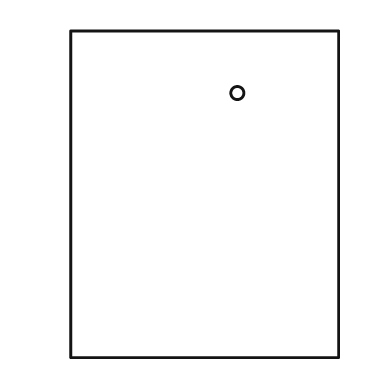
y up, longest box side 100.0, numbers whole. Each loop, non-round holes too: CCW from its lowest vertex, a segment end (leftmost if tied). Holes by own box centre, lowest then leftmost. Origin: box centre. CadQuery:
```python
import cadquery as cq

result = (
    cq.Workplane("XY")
    .moveTo(-41.0, -50.0)
    .lineTo(41.0, -50.0)
    .lineTo(41.0, 50.0)
    .lineTo(-41.0, 50.0)
    .close()
    .moveTo(10.0, 31.0)
    .circle(2.0)
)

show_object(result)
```